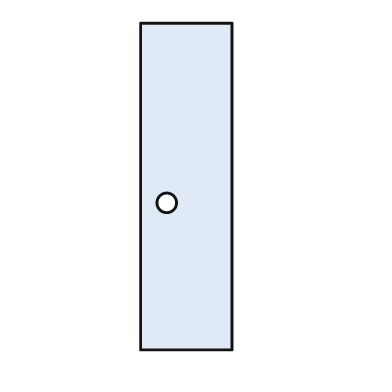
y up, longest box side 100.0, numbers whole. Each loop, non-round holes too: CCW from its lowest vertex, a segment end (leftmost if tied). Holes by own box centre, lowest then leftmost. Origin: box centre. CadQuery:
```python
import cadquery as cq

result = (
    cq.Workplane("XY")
    .moveTo(-14.0, -50.0)
    .lineTo(14.0, -50.0)
    .lineTo(14.0, 50.0)
    .lineTo(-14.0, 50.0)
    .close()
    .moveTo(-6.0, -5.0)
    .circle(3.0)
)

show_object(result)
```